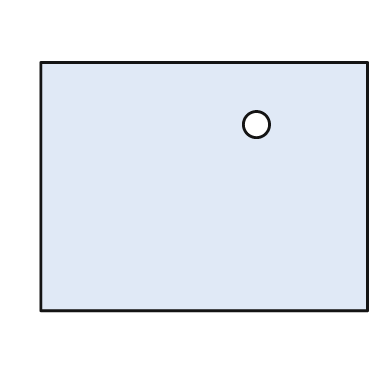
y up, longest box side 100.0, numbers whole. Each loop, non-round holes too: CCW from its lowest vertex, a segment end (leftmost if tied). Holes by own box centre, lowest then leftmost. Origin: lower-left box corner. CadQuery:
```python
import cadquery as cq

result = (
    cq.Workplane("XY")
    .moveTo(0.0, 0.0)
    .lineTo(100.0, 0.0)
    .lineTo(100.0, 76.0)
    .lineTo(0.0, 76.0)
    .close()
    .moveTo(66.0, 57.0)
    .circle(4.0)
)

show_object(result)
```